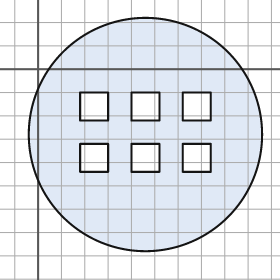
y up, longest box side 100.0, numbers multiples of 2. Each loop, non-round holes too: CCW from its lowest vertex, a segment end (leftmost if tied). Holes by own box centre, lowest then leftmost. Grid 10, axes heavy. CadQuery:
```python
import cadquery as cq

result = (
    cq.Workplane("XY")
    .moveTo(46.0, -28.0)
    .circle(50.0)
    .moveTo(18.0, -44.0)
    .lineTo(30.0, -44.0)
    .lineTo(30.0, -32.0)
    .lineTo(18.0, -32.0)
    .close()
    .moveTo(40.0, -44.0)
    .lineTo(52.0, -44.0)
    .lineTo(52.0, -32.0)
    .lineTo(40.0, -32.0)
    .close()
    .moveTo(62.0, -44.0)
    .lineTo(74.0, -44.0)
    .lineTo(74.0, -32.0)
    .lineTo(62.0, -32.0)
    .close()
    .moveTo(18.0, -22.0)
    .lineTo(30.0, -22.0)
    .lineTo(30.0, -10.0)
    .lineTo(18.0, -10.0)
    .close()
    .moveTo(40.0, -22.0)
    .lineTo(52.0, -22.0)
    .lineTo(52.0, -10.0)
    .lineTo(40.0, -10.0)
    .close()
    .moveTo(62.0, -22.0)
    .lineTo(74.0, -22.0)
    .lineTo(74.0, -10.0)
    .lineTo(62.0, -10.0)
    .close()
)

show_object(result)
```